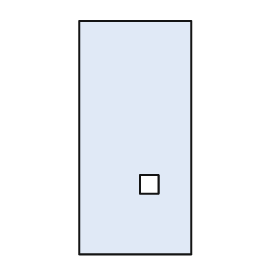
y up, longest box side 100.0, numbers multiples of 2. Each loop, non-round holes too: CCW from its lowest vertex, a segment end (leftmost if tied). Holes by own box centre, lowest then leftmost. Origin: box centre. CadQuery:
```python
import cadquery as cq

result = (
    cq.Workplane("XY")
    .moveTo(-24.0, -50.0)
    .lineTo(24.0, -50.0)
    .lineTo(24.0, 50.0)
    .lineTo(-24.0, 50.0)
    .close()
    .moveTo(2.0, -24.0)
    .lineTo(10.0, -24.0)
    .lineTo(10.0, -16.0)
    .lineTo(2.0, -16.0)
    .close()
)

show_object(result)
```